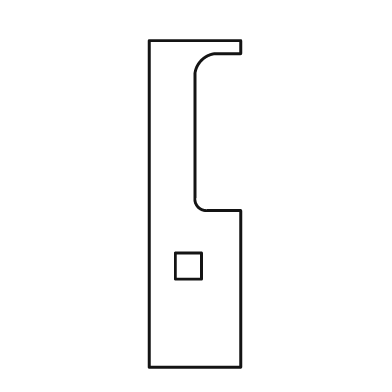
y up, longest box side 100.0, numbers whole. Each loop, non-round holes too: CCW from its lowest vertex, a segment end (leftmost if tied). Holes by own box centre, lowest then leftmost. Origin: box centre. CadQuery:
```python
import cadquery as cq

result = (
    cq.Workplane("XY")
    .moveTo(-14.0, -50.0)
    .lineTo(14.0, -50.0)
    .lineTo(14.0, -2.0)
    .lineTo(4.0, -2.0)
    .threePointArc((1.0, -1.0), (0.0, 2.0))
    .lineTo(0.0, 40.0)
    .threePointArc((2.0, 44.0), (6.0, 46.0))
    .lineTo(14.0, 46.0)
    .lineTo(14.0, 50.0)
    .lineTo(-14.0, 50.0)
    .close()
    .moveTo(-6.0, -23.0)
    .lineTo(2.0, -23.0)
    .lineTo(2.0, -15.0)
    .lineTo(-6.0, -15.0)
    .close()
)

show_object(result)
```